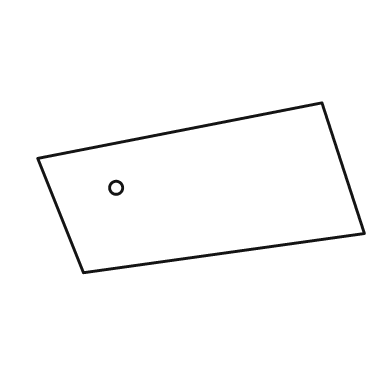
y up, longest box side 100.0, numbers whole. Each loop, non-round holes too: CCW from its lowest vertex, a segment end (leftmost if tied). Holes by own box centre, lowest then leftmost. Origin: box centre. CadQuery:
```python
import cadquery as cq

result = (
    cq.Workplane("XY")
    .moveTo(-36.0, -26.0)
    .lineTo(50.0, -14.0)
    .lineTo(37.0, 26.0)
    .lineTo(-50.0, 9.0)
    .close()
    .moveTo(-26.0, 0.0)
    .circle(2.0)
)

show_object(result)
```